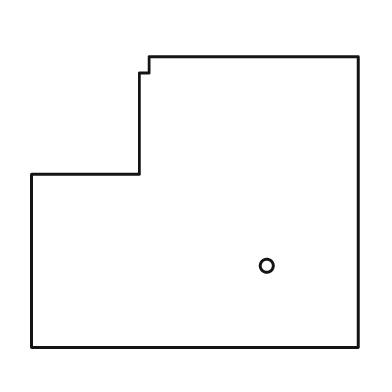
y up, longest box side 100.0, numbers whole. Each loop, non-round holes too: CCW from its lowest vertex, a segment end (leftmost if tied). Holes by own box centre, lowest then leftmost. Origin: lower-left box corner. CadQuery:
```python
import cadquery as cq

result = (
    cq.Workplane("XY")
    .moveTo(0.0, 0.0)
    .lineTo(100.0, 0.0)
    .lineTo(100.0, 89.0)
    .lineTo(36.0, 89.0)
    .lineTo(36.0, 84.0)
    .lineTo(33.0, 84.0)
    .lineTo(33.0, 53.0)
    .lineTo(0.0, 53.0)
    .close()
    .moveTo(72.0, 25.0)
    .circle(2.0)
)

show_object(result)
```